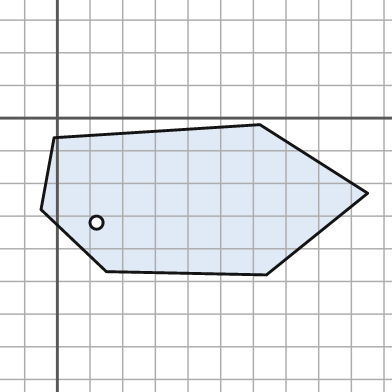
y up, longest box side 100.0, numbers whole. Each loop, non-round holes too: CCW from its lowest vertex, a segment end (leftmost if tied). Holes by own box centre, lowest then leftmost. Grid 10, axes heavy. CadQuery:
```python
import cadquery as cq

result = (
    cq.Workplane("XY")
    .moveTo(64.0, -48.0)
    .lineTo(95.0, -23.0)
    .lineTo(62.0, -2.0)
    .lineTo(-1.0, -6.0)
    .lineTo(-5.0, -28.0)
    .lineTo(15.0, -47.0)
    .close()
    .moveTo(12.0, -32.0)
    .circle(2.0)
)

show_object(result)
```